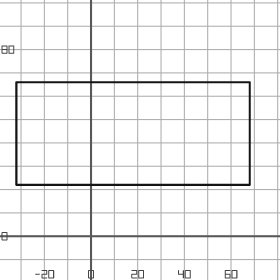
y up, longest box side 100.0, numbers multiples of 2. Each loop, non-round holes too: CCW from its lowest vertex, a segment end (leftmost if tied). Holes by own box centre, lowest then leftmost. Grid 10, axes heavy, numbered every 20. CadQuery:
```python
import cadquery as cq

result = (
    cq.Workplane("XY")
    .moveTo(-32.0, 22.0)
    .lineTo(68.0, 22.0)
    .lineTo(68.0, 66.0)
    .lineTo(-32.0, 66.0)
    .close()
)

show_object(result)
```